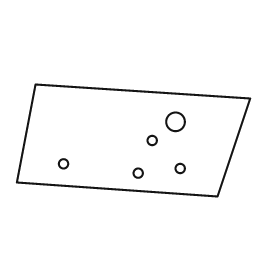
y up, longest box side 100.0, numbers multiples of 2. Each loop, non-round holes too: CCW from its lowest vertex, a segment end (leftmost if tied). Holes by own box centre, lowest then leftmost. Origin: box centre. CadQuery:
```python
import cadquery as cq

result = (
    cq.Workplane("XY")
    .moveTo(36.0, -24.0)
    .lineTo(50.0, 18.0)
    .lineTo(-42.0, 24.0)
    .lineTo(-50.0, -18.0)
    .close()
    .moveTo(2.0, -14.0)
    .circle(2.0)
    .moveTo(20.0, -12.0)
    .circle(2.0)
    .moveTo(-30.0, -10.0)
    .circle(2.0)
    .moveTo(8.0, 0.0)
    .circle(2.0)
    .moveTo(18.0, 8.0)
    .circle(4.0)
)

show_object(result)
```